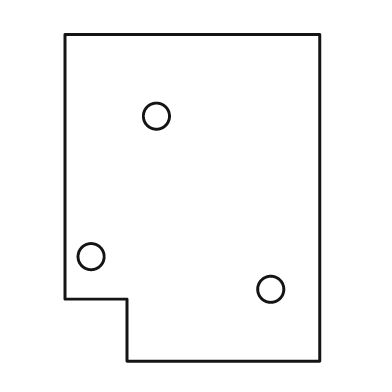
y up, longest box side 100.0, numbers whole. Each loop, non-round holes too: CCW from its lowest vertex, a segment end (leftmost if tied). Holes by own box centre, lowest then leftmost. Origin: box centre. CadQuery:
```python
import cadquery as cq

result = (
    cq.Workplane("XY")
    .moveTo(-20.0, -50.0)
    .lineTo(39.0, -50.0)
    .lineTo(39.0, 50.0)
    .lineTo(-39.0, 50.0)
    .lineTo(-39.0, -31.0)
    .lineTo(-20.0, -31.0)
    .close()
    .moveTo(24.0, -28.0)
    .circle(4.0)
    .moveTo(-31.0, -18.0)
    .circle(4.0)
    .moveTo(-11.0, 25.0)
    .circle(4.0)
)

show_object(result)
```